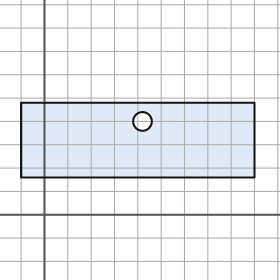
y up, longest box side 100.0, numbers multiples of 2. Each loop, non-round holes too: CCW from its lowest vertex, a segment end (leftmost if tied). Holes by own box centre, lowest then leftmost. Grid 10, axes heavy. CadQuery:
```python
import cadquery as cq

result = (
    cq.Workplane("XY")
    .moveTo(-10.0, 16.0)
    .lineTo(90.0, 16.0)
    .lineTo(90.0, 48.0)
    .lineTo(-10.0, 48.0)
    .close()
    .moveTo(42.0, 40.0)
    .circle(4.0)
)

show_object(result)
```